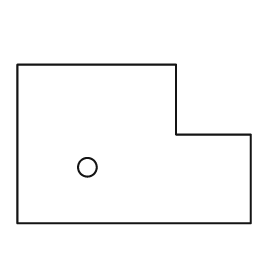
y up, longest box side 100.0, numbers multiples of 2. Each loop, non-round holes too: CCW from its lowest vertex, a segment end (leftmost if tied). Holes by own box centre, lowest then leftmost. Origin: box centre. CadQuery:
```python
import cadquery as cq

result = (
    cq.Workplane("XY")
    .moveTo(-50.0, -34.0)
    .lineTo(50.0, -34.0)
    .lineTo(50.0, 4.0)
    .lineTo(18.0, 4.0)
    .lineTo(18.0, 34.0)
    .lineTo(-50.0, 34.0)
    .close()
    .moveTo(-20.0, -10.0)
    .circle(4.0)
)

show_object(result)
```